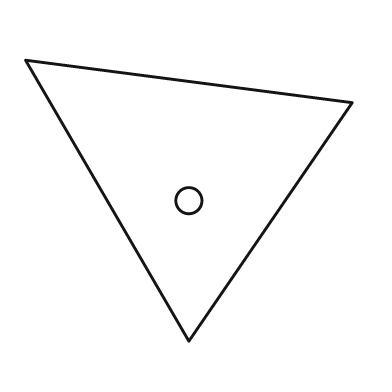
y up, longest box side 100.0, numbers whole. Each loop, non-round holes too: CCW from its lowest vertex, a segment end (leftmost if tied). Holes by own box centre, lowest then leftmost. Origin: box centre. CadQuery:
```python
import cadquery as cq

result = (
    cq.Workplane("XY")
    .moveTo(0.0, -43.0)
    .lineTo(50.0, 30.0)
    .lineTo(-50.0, 43.0)
    .close()
    .moveTo(0.0, 0.0)
    .circle(4.0)
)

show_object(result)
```